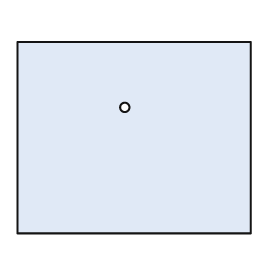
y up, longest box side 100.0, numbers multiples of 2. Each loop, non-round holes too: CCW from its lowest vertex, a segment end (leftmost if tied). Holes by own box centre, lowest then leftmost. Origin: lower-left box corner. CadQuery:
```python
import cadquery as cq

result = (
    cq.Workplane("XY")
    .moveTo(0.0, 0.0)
    .lineTo(100.0, 0.0)
    .lineTo(100.0, 82.0)
    .lineTo(0.0, 82.0)
    .close()
    .moveTo(46.0, 54.0)
    .circle(2.0)
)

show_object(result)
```